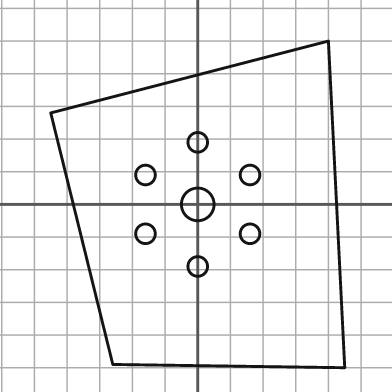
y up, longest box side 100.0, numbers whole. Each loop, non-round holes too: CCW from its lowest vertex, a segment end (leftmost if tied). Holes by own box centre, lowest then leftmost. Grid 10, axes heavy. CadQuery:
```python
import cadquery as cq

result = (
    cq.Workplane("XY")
    .moveTo(45.0, -50.0)
    .lineTo(40.0, 50.0)
    .lineTo(-45.0, 28.0)
    .lineTo(-26.0, -49.0)
    .close()
    .moveTo(0.0, -19.0)
    .circle(3.0)
    .moveTo(-16.0, -9.0)
    .circle(3.0)
    .moveTo(16.0, -9.0)
    .circle(3.0)
    .moveTo(0.0, 0.0)
    .circle(5.0)
    .moveTo(-16.0, 9.0)
    .circle(3.0)
    .moveTo(16.0, 9.0)
    .circle(3.0)
    .moveTo(0.0, 19.0)
    .circle(3.0)
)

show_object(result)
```